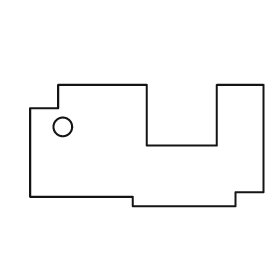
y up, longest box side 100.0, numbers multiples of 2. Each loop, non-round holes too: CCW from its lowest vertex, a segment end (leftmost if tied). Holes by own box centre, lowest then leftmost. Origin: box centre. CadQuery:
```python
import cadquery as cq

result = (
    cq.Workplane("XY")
    .moveTo(-6.0, -26.0)
    .lineTo(38.0, -26.0)
    .lineTo(38.0, -20.0)
    .lineTo(50.0, -20.0)
    .lineTo(50.0, 26.0)
    .lineTo(30.0, 26.0)
    .lineTo(30.0, 0.0)
    .lineTo(0.0, 0.0)
    .lineTo(0.0, 26.0)
    .lineTo(-38.0, 26.0)
    .lineTo(-38.0, 16.0)
    .lineTo(-50.0, 16.0)
    .lineTo(-50.0, -22.0)
    .lineTo(-6.0, -22.0)
    .close()
    .moveTo(-36.0, 8.0)
    .circle(4.0)
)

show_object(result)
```